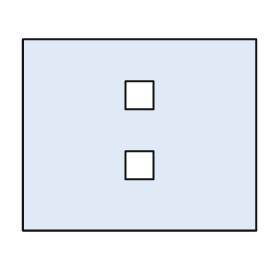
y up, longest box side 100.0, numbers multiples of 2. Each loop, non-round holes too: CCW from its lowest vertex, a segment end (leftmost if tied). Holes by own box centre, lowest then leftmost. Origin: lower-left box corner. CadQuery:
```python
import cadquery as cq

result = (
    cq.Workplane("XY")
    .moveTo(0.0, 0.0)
    .lineTo(100.0, 0.0)
    .lineTo(100.0, 82.0)
    .lineTo(0.0, 82.0)
    .close()
    .moveTo(44.0, 22.0)
    .lineTo(56.0, 22.0)
    .lineTo(56.0, 34.0)
    .lineTo(44.0, 34.0)
    .close()
    .moveTo(44.0, 52.0)
    .lineTo(56.0, 52.0)
    .lineTo(56.0, 64.0)
    .lineTo(44.0, 64.0)
    .close()
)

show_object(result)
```